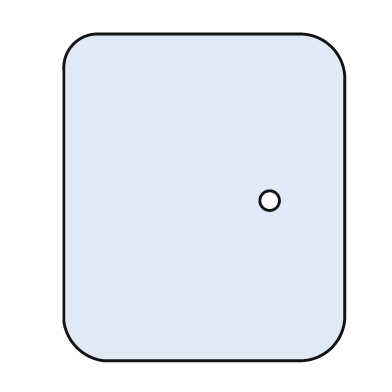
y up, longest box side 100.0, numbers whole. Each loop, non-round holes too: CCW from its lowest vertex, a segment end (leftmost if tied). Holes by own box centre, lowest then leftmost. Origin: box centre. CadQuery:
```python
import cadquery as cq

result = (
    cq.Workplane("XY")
    .moveTo(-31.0, -50.0)
    .lineTo(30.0, -50.0)
    .threePointArc((39.0, -46.0), (43.0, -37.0))
    .lineTo(43.0, 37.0)
    .threePointArc((39.0, 46.0), (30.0, 50.0))
    .lineTo(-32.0, 50.0)
    .threePointArc((-40.0, 47.0), (-43.0, 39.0))
    .lineTo(-43.0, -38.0)
    .threePointArc((-39.0, -46.0), (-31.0, -50.0))
    .close()
    .moveTo(20.0, -1.0)
    .circle(3.0)
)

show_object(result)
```